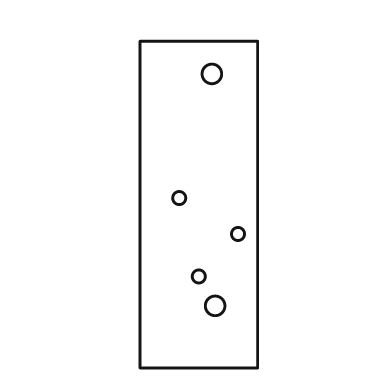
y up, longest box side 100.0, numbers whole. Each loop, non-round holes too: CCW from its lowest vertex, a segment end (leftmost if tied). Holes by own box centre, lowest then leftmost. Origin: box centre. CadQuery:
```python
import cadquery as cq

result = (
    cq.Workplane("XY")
    .moveTo(-18.0, -50.0)
    .lineTo(18.0, -50.0)
    .lineTo(18.0, 50.0)
    .lineTo(-18.0, 50.0)
    .close()
    .moveTo(5.0, -31.0)
    .circle(3.0)
    .moveTo(0.0, -22.0)
    .circle(2.0)
    .moveTo(12.0, -9.0)
    .circle(2.0)
    .moveTo(-6.0, 2.0)
    .circle(2.0)
    .moveTo(4.0, 40.0)
    .circle(3.0)
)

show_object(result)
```